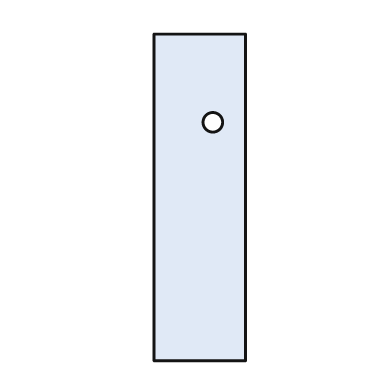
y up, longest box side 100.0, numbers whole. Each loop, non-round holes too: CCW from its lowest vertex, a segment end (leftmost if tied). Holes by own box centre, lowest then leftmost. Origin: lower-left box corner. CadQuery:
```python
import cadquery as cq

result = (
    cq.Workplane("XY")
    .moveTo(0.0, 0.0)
    .lineTo(28.0, 0.0)
    .lineTo(28.0, 100.0)
    .lineTo(0.0, 100.0)
    .close()
    .moveTo(18.0, 73.0)
    .circle(3.0)
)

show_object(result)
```